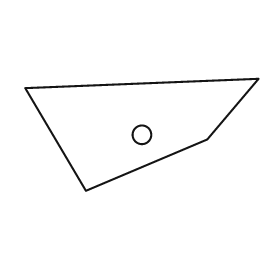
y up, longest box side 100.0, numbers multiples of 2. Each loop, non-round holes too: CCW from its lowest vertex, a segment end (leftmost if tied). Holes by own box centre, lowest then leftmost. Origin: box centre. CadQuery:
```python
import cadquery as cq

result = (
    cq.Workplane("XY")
    .moveTo(-24.0, -24.0)
    .lineTo(28.0, -2.0)
    .lineTo(50.0, 24.0)
    .lineTo(-50.0, 20.0)
    .close()
    .moveTo(0.0, 0.0)
    .circle(4.0)
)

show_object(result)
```